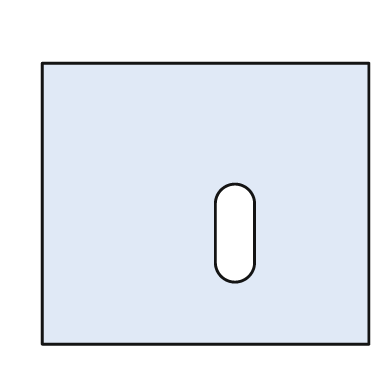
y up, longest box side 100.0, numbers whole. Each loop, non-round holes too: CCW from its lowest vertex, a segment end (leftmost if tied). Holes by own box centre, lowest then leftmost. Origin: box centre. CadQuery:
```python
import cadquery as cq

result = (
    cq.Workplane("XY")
    .moveTo(-50.0, -43.0)
    .lineTo(50.0, -43.0)
    .lineTo(50.0, 43.0)
    .lineTo(-50.0, 43.0)
    .close()
    .moveTo(3.0, -18.0)
    .threePointArc((9.0, -24.0), (15.0, -18.0))
    .lineTo(15.0, 0.0)
    .threePointArc((9.0, 6.0), (3.0, 0.0))
    .close()
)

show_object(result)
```